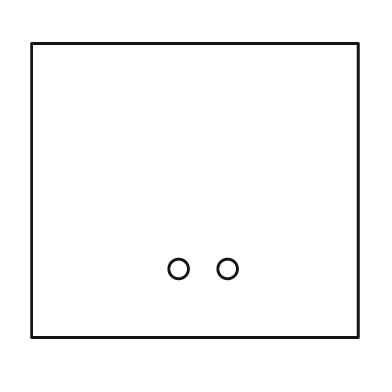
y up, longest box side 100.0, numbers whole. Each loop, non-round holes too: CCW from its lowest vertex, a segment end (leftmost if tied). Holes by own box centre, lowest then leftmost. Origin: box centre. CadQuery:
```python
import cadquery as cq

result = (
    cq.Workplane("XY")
    .moveTo(-50.0, -45.0)
    .lineTo(50.0, -45.0)
    .lineTo(50.0, 45.0)
    .lineTo(-50.0, 45.0)
    .close()
    .moveTo(-5.0, -24.0)
    .circle(3.0)
    .moveTo(10.0, -24.0)
    .circle(3.0)
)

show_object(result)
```